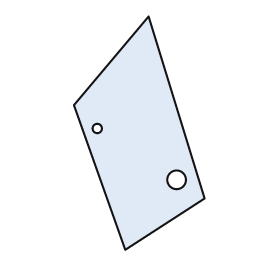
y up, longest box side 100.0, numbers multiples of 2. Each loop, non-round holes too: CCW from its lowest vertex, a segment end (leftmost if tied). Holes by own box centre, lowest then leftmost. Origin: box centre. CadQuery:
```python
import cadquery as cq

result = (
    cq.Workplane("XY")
    .moveTo(-6.0, -50.0)
    .lineTo(28.0, -28.0)
    .lineTo(4.0, 50.0)
    .lineTo(-28.0, 12.0)
    .close()
    .moveTo(16.0, -20.0)
    .circle(4.0)
    .moveTo(-18.0, 2.0)
    .circle(2.0)
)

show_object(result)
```